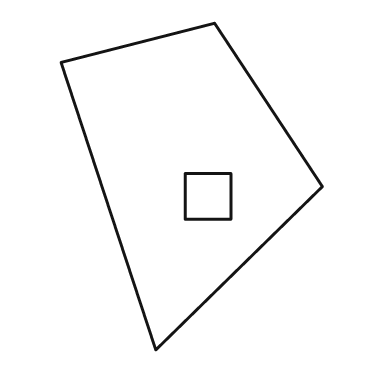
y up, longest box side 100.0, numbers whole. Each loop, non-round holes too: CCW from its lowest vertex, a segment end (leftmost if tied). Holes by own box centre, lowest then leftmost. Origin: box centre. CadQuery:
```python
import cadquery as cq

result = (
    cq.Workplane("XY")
    .moveTo(-11.0, -50.0)
    .lineTo(40.0, 0.0)
    .lineTo(7.0, 50.0)
    .lineTo(-40.0, 38.0)
    .close()
    .moveTo(-2.0, -10.0)
    .lineTo(12.0, -10.0)
    .lineTo(12.0, 4.0)
    .lineTo(-2.0, 4.0)
    .close()
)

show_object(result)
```